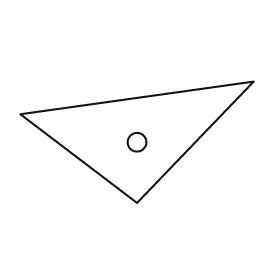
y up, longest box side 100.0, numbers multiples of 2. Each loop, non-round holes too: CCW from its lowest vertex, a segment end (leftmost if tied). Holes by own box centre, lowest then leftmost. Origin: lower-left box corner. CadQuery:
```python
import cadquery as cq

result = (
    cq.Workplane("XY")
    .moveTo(50.0, 0.0)
    .lineTo(100.0, 52.0)
    .lineTo(0.0, 38.0)
    .close()
    .moveTo(50.0, 26.0)
    .circle(4.0)
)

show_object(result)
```